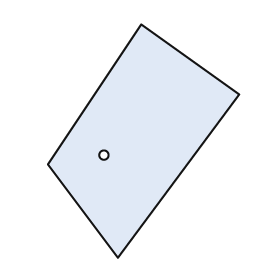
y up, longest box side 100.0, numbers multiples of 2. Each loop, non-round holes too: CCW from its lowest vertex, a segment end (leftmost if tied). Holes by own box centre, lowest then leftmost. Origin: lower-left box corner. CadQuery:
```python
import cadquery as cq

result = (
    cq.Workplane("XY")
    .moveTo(30.0, 0.0)
    .lineTo(82.0, 70.0)
    .lineTo(40.0, 100.0)
    .lineTo(0.0, 40.0)
    .close()
    .moveTo(24.0, 44.0)
    .circle(2.0)
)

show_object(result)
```